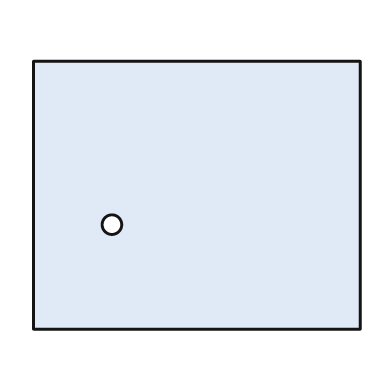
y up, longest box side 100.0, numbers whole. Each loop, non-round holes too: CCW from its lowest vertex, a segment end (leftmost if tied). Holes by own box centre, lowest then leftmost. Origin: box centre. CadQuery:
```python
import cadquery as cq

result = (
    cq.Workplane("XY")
    .moveTo(-50.0, -41.0)
    .lineTo(50.0, -41.0)
    .lineTo(50.0, 41.0)
    .lineTo(-50.0, 41.0)
    .close()
    .moveTo(-26.0, -9.0)
    .circle(3.0)
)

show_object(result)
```